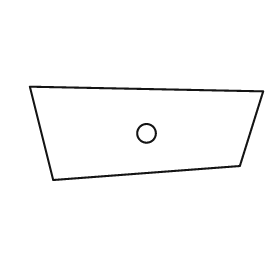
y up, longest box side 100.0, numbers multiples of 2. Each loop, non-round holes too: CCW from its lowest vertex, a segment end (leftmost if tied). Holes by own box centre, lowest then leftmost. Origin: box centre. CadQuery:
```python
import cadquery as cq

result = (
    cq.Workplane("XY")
    .moveTo(-40.0, -20.0)
    .lineTo(40.0, -14.0)
    .lineTo(50.0, 18.0)
    .lineTo(-50.0, 20.0)
    .close()
    .moveTo(0.0, 0.0)
    .circle(4.0)
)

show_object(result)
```